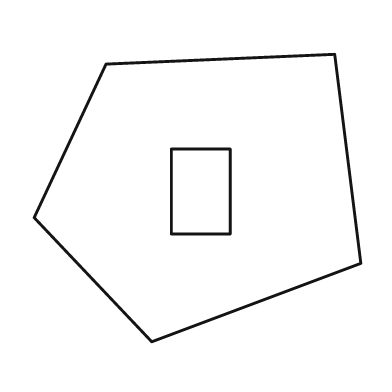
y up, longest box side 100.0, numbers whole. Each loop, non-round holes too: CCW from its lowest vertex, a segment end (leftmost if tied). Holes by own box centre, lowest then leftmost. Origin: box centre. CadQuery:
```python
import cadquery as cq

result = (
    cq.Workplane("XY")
    .moveTo(-14.0, -44.0)
    .lineTo(50.0, -20.0)
    .lineTo(42.0, 44.0)
    .lineTo(-28.0, 41.0)
    .lineTo(-50.0, -6.0)
    .close()
    .moveTo(-8.0, -11.0)
    .lineTo(10.0, -11.0)
    .lineTo(10.0, 15.0)
    .lineTo(-8.0, 15.0)
    .close()
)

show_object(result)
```